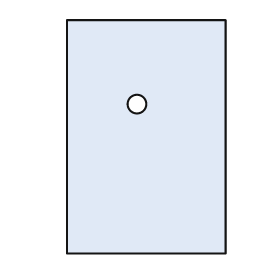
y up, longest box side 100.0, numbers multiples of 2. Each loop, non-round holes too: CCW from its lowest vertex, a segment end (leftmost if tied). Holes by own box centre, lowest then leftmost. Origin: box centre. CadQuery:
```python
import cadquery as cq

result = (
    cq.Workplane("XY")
    .moveTo(-34.0, -50.0)
    .lineTo(34.0, -50.0)
    .lineTo(34.0, 50.0)
    .lineTo(-34.0, 50.0)
    .close()
    .moveTo(-4.0, 14.0)
    .circle(4.0)
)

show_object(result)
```